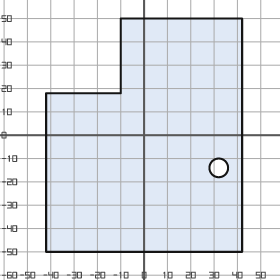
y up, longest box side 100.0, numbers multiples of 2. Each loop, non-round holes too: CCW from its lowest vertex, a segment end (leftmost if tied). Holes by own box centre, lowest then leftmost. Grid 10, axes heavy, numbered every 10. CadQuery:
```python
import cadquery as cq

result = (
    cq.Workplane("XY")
    .moveTo(-42.0, -50.0)
    .lineTo(42.0, -50.0)
    .lineTo(42.0, 50.0)
    .lineTo(-10.0, 50.0)
    .lineTo(-10.0, 18.0)
    .lineTo(-42.0, 18.0)
    .close()
    .moveTo(32.0, -14.0)
    .circle(4.0)
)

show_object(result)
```